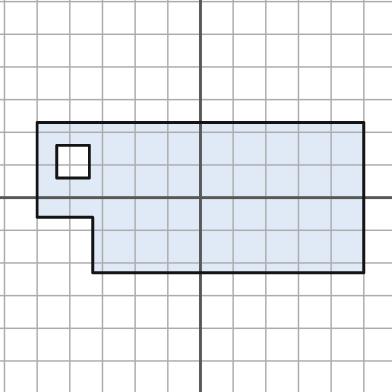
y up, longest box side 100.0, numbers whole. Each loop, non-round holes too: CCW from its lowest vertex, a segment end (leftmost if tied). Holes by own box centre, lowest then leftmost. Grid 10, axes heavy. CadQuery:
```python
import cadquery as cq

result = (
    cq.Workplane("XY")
    .moveTo(-33.0, -23.0)
    .lineTo(50.0, -23.0)
    .lineTo(50.0, 23.0)
    .lineTo(-50.0, 23.0)
    .lineTo(-50.0, -6.0)
    .lineTo(-33.0, -6.0)
    .close()
    .moveTo(-44.0, 6.0)
    .lineTo(-34.0, 6.0)
    .lineTo(-34.0, 16.0)
    .lineTo(-44.0, 16.0)
    .close()
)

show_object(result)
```